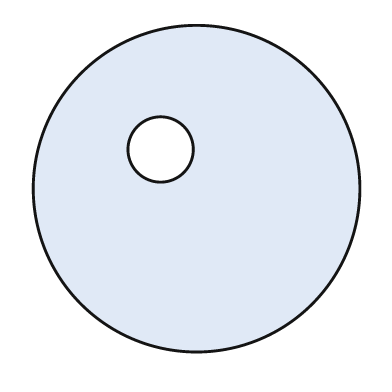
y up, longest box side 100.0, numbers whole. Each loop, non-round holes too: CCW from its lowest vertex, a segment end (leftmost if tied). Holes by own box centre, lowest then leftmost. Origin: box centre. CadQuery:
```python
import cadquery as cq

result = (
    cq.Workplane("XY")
    .moveTo(0.0, 0.0)
    .circle(50.0)
    .moveTo(-11.0, 12.0)
    .circle(10.0)
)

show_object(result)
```